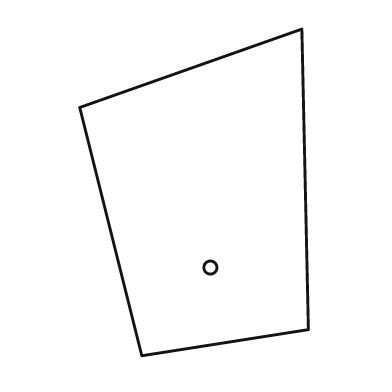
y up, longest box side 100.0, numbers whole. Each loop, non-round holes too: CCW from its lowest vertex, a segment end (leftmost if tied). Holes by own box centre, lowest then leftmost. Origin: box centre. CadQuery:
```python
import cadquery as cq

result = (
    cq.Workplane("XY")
    .moveTo(-16.0, -50.0)
    .lineTo(35.0, -42.0)
    .lineTo(33.0, 50.0)
    .lineTo(-35.0, 26.0)
    .close()
    .moveTo(5.0, -23.0)
    .circle(2.0)
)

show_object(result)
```